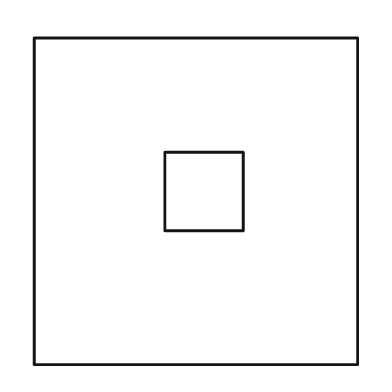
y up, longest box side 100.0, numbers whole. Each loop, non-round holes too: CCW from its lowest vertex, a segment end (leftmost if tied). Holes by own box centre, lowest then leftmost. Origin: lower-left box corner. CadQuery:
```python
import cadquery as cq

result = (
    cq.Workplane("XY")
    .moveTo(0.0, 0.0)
    .lineTo(99.0, 0.0)
    .lineTo(99.0, 100.0)
    .lineTo(0.0, 100.0)
    .close()
    .moveTo(40.0, 41.0)
    .lineTo(64.0, 41.0)
    .lineTo(64.0, 65.0)
    .lineTo(40.0, 65.0)
    .close()
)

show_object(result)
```